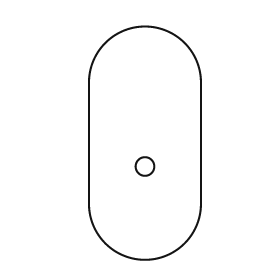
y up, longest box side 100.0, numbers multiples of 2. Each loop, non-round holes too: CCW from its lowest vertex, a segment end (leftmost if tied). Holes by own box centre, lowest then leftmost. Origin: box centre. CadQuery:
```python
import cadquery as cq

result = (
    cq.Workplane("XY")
    .moveTo(-24.0, -26.0)
    .threePointArc((0.0, -50.0), (24.0, -26.0))
    .lineTo(24.0, 26.0)
    .threePointArc((0.0, 50.0), (-24.0, 26.0))
    .close()
    .moveTo(0.0, -10.0)
    .circle(4.0)
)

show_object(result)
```